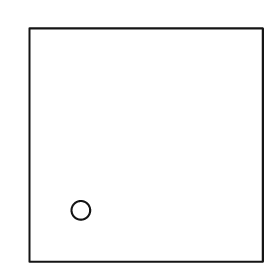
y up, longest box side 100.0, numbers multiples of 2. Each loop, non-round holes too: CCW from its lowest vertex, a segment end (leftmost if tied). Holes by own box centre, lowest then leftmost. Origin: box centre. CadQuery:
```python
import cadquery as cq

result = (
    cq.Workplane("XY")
    .moveTo(-50.0, -50.0)
    .lineTo(50.0, -50.0)
    .lineTo(50.0, 50.0)
    .lineTo(-50.0, 50.0)
    .close()
    .moveTo(-28.0, -28.0)
    .circle(4.0)
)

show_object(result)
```